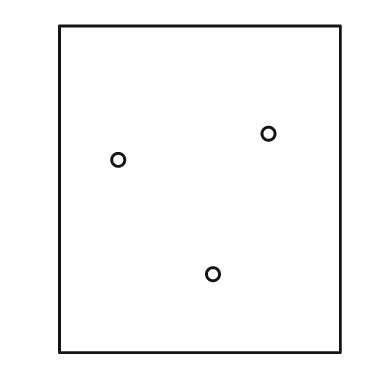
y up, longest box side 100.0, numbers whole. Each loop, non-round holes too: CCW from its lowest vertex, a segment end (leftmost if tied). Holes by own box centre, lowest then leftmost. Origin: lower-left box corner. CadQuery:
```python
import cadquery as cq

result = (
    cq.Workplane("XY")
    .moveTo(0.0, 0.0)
    .lineTo(86.0, 0.0)
    .lineTo(86.0, 100.0)
    .lineTo(0.0, 100.0)
    .close()
    .moveTo(47.0, 24.0)
    .circle(2.0)
    .moveTo(18.0, 59.0)
    .circle(2.0)
    .moveTo(64.0, 67.0)
    .circle(2.0)
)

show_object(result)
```